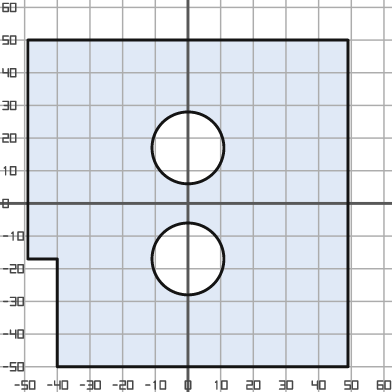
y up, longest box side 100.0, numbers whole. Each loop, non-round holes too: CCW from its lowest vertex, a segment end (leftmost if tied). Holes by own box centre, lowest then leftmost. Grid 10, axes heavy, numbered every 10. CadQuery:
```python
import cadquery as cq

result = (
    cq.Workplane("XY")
    .moveTo(-40.0, -50.0)
    .lineTo(49.0, -50.0)
    .lineTo(49.0, 50.0)
    .lineTo(-49.0, 50.0)
    .lineTo(-49.0, -17.0)
    .lineTo(-40.0, -17.0)
    .close()
    .moveTo(0.0, -17.0)
    .circle(11.0)
    .moveTo(0.0, 17.0)
    .circle(11.0)
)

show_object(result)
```